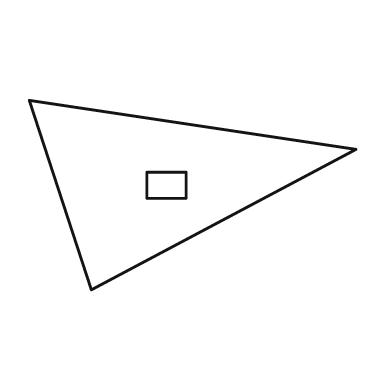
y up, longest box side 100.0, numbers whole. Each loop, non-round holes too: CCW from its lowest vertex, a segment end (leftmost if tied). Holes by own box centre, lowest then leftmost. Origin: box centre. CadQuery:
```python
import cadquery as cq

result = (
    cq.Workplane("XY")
    .moveTo(-31.0, -29.0)
    .lineTo(50.0, 14.0)
    .lineTo(-50.0, 29.0)
    .close()
    .moveTo(-14.0, -1.0)
    .lineTo(-2.0, -1.0)
    .lineTo(-2.0, 7.0)
    .lineTo(-14.0, 7.0)
    .close()
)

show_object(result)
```